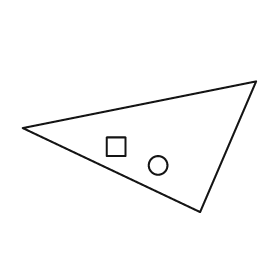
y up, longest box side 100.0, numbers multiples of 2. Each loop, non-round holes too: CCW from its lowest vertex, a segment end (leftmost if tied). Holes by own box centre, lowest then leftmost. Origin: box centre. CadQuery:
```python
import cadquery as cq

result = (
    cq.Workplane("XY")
    .moveTo(26.0, -28.0)
    .lineTo(50.0, 28.0)
    .lineTo(-50.0, 8.0)
    .close()
    .moveTo(8.0, -8.0)
    .circle(4.0)
    .moveTo(-14.0, -4.0)
    .lineTo(-6.0, -4.0)
    .lineTo(-6.0, 4.0)
    .lineTo(-14.0, 4.0)
    .close()
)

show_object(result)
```